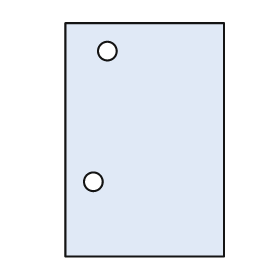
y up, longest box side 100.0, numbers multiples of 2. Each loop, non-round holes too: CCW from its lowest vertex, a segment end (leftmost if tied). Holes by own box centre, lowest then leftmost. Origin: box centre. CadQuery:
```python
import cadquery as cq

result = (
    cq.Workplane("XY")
    .moveTo(-34.0, -50.0)
    .lineTo(34.0, -50.0)
    .lineTo(34.0, 50.0)
    .lineTo(-34.0, 50.0)
    .close()
    .moveTo(-22.0, -18.0)
    .circle(4.0)
    .moveTo(-16.0, 38.0)
    .circle(4.0)
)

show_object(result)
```